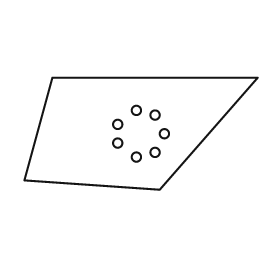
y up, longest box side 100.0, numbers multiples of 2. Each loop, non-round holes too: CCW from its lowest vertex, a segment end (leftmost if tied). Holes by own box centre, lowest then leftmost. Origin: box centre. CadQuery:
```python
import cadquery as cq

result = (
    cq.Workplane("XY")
    .moveTo(8.0, -24.0)
    .lineTo(50.0, 24.0)
    .lineTo(-38.0, 24.0)
    .lineTo(-50.0, -20.0)
    .close()
    .moveTo(-2.0, -10.0)
    .circle(2.0)
    .moveTo(6.0, -8.0)
    .circle(2.0)
    .moveTo(-10.0, -4.0)
    .circle(2.0)
    .moveTo(10.0, 0.0)
    .circle(2.0)
    .moveTo(-10.0, 4.0)
    .circle(2.0)
    .moveTo(6.0, 8.0)
    .circle(2.0)
    .moveTo(-2.0, 10.0)
    .circle(2.0)
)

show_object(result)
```